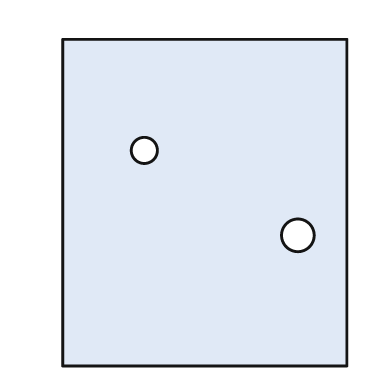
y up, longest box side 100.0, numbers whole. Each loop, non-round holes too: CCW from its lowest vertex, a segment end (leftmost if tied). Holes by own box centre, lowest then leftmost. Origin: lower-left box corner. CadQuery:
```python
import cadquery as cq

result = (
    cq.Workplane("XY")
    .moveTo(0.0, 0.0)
    .lineTo(87.0, 0.0)
    .lineTo(87.0, 100.0)
    .lineTo(0.0, 100.0)
    .close()
    .moveTo(72.0, 40.0)
    .circle(5.0)
    .moveTo(25.0, 66.0)
    .circle(4.0)
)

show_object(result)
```